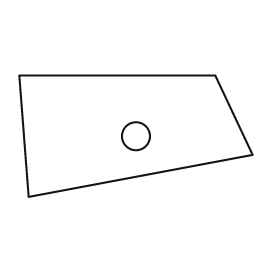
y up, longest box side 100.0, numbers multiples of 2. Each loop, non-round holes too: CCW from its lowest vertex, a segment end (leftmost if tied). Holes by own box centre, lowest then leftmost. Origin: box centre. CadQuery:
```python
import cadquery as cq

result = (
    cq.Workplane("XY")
    .moveTo(-46.0, -26.0)
    .lineTo(50.0, -8.0)
    .lineTo(34.0, 26.0)
    .lineTo(-50.0, 26.0)
    .close()
    .moveTo(0.0, 0.0)
    .circle(6.0)
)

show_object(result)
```